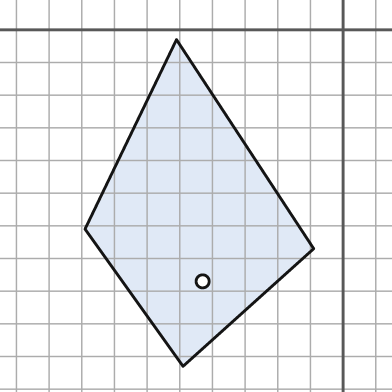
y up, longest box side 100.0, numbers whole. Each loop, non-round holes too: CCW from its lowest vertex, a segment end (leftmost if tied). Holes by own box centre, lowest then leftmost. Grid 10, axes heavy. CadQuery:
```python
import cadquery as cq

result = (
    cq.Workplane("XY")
    .moveTo(-49.0, -103.0)
    .lineTo(-9.0, -67.0)
    .lineTo(-51.0, -3.0)
    .lineTo(-79.0, -61.0)
    .close()
    .moveTo(-43.0, -77.0)
    .circle(2.0)
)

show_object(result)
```